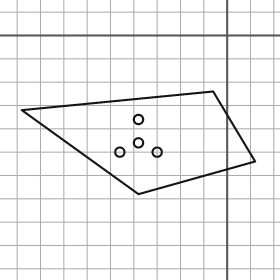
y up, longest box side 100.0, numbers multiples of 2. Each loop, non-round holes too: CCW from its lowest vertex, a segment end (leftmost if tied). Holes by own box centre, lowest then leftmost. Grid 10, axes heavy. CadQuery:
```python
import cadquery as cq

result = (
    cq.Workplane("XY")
    .moveTo(-38.0, -68.0)
    .lineTo(12.0, -54.0)
    .lineTo(-6.0, -24.0)
    .lineTo(-88.0, -32.0)
    .close()
    .moveTo(-46.0, -50.0)
    .circle(2.0)
    .moveTo(-30.0, -50.0)
    .circle(2.0)
    .moveTo(-38.0, -46.0)
    .circle(2.0)
    .moveTo(-38.0, -36.0)
    .circle(2.0)
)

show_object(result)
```